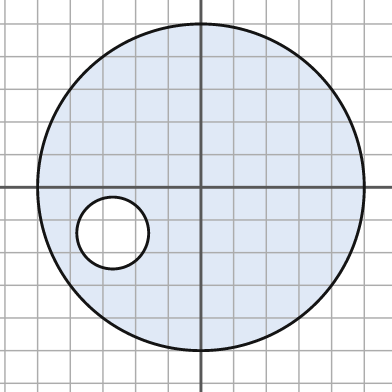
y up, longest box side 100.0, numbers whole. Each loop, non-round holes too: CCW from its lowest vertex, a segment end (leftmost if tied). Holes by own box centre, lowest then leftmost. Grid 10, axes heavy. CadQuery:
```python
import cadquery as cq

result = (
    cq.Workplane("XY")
    .moveTo(0.0, 0.0)
    .circle(50.0)
    .moveTo(-27.0, -14.0)
    .circle(11.0)
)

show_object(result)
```